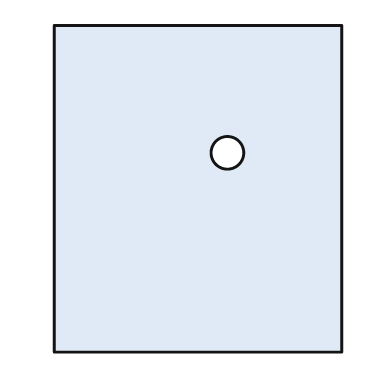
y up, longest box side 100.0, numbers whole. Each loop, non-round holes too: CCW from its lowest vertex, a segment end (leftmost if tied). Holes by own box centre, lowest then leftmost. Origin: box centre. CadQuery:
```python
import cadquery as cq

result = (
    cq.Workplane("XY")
    .moveTo(-44.0, -50.0)
    .lineTo(44.0, -50.0)
    .lineTo(44.0, 50.0)
    .lineTo(-44.0, 50.0)
    .close()
    .moveTo(9.0, 11.0)
    .circle(5.0)
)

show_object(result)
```